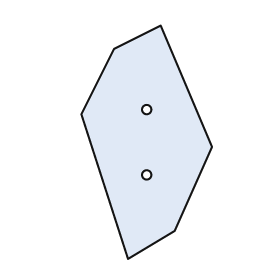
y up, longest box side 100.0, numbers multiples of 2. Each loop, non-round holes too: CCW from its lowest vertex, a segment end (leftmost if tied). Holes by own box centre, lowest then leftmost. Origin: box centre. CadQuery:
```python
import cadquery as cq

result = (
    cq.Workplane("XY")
    .moveTo(-8.0, -50.0)
    .lineTo(12.0, -38.0)
    .lineTo(28.0, -2.0)
    .lineTo(6.0, 50.0)
    .lineTo(-14.0, 40.0)
    .lineTo(-28.0, 12.0)
    .close()
    .moveTo(0.0, -14.0)
    .circle(2.0)
    .moveTo(0.0, 14.0)
    .circle(2.0)
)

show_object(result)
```